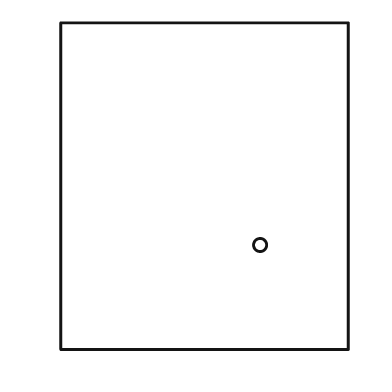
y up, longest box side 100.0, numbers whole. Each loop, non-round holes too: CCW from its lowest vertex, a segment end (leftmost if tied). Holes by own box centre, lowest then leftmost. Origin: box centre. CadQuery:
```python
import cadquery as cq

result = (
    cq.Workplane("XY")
    .moveTo(-44.0, -50.0)
    .lineTo(44.0, -50.0)
    .lineTo(44.0, 50.0)
    .lineTo(-44.0, 50.0)
    .close()
    .moveTo(17.0, -18.0)
    .circle(2.0)
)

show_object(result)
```